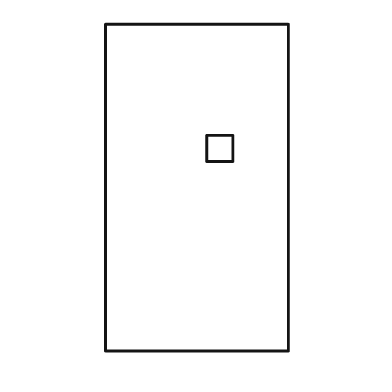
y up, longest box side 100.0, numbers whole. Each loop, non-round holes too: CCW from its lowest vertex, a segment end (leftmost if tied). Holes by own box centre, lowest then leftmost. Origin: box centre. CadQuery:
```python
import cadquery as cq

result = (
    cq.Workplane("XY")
    .moveTo(-28.0, -50.0)
    .lineTo(28.0, -50.0)
    .lineTo(28.0, 50.0)
    .lineTo(-28.0, 50.0)
    .close()
    .moveTo(3.0, 8.0)
    .lineTo(11.0, 8.0)
    .lineTo(11.0, 16.0)
    .lineTo(3.0, 16.0)
    .close()
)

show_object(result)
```